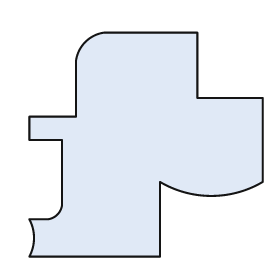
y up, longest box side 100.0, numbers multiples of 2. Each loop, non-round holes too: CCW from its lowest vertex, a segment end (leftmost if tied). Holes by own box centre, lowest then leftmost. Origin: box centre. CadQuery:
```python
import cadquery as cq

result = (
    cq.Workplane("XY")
    .moveTo(-50.0, -48.0)
    .lineTo(6.0, -48.0)
    .lineTo(6.0, -16.0)
    .threePointArc((28.0, -22.0), (50.0, -16.0))
    .lineTo(50.0, 20.0)
    .lineTo(22.0, 20.0)
    .lineTo(22.0, 48.0)
    .lineTo(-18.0, 48.0)
    .threePointArc((-26.0, 44.0), (-30.0, 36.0))
    .lineTo(-30.0, 12.0)
    .lineTo(-50.0, 12.0)
    .lineTo(-50.0, 2.0)
    .lineTo(-36.0, 2.0)
    .lineTo(-36.0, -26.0)
    .threePointArc((-38.0, -30.0), (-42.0, -32.0))
    .lineTo(-50.0, -32.0)
    .threePointArc((-48.0, -40.0), (-50.0, -48.0))
    .close()
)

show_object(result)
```